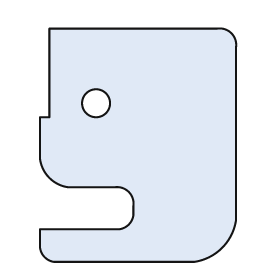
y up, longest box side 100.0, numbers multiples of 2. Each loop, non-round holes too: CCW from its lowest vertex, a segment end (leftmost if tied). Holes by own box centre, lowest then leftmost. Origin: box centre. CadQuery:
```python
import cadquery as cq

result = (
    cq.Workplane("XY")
    .moveTo(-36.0, -50.0)
    .lineTo(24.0, -50.0)
    .threePointArc((36.0, -44.0), (42.0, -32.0))
    .lineTo(42.0, 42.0)
    .threePointArc((40.0, 48.0), (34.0, 50.0))
    .lineTo(-38.0, 50.0)
    .lineTo(-38.0, 12.0)
    .lineTo(-42.0, 12.0)
    .lineTo(-42.0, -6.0)
    .threePointArc((-38.0, -14.0), (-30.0, -18.0))
    .lineTo(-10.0, -18.0)
    .threePointArc((-4.0, -20.0), (-2.0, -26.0))
    .lineTo(-2.0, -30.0)
    .threePointArc((-4.0, -34.0), (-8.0, -36.0))
    .lineTo(-42.0, -36.0)
    .lineTo(-42.0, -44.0)
    .threePointArc((-40.0, -48.0), (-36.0, -50.0))
    .close()
    .moveTo(-18.0, 18.0)
    .circle(6.0)
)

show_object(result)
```